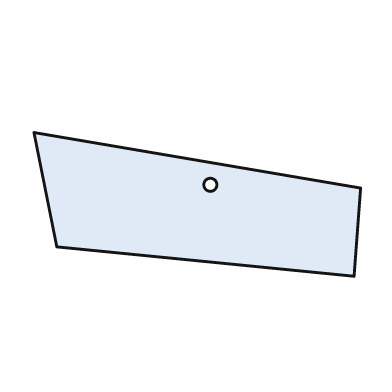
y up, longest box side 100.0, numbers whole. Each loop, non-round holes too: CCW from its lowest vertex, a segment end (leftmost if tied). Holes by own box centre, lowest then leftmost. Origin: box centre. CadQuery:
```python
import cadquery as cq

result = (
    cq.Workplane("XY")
    .moveTo(48.0, -22.0)
    .lineTo(50.0, 5.0)
    .lineTo(-50.0, 22.0)
    .lineTo(-43.0, -13.0)
    .close()
    .moveTo(4.0, 6.0)
    .circle(2.0)
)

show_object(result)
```